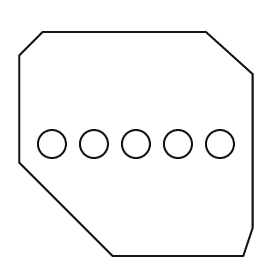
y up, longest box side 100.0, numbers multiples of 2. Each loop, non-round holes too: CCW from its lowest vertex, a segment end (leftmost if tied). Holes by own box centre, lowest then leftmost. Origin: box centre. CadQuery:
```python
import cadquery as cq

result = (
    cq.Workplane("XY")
    .moveTo(-10.0, -48.0)
    .lineTo(46.0, -48.0)
    .lineTo(50.0, -36.0)
    .lineTo(50.0, 30.0)
    .lineTo(30.0, 48.0)
    .lineTo(-40.0, 48.0)
    .lineTo(-50.0, 38.0)
    .lineTo(-50.0, -8.0)
    .close()
    .moveTo(-36.0, 0.0)
    .circle(6.0)
    .moveTo(-18.0, 0.0)
    .circle(6.0)
    .moveTo(0.0, 0.0)
    .circle(6.0)
    .moveTo(18.0, 0.0)
    .circle(6.0)
    .moveTo(36.0, 0.0)
    .circle(6.0)
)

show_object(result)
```